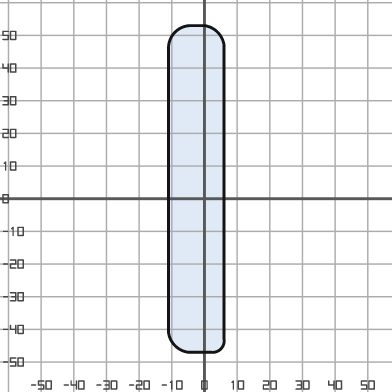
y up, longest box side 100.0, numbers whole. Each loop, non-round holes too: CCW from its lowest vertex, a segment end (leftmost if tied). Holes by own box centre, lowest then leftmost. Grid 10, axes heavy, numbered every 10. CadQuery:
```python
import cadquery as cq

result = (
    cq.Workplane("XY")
    .moveTo(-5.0, -47.0)
    .lineTo(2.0, -47.0)
    .threePointArc((5.0, -46.0), (6.0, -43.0))
    .lineTo(6.0, 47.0)
    .threePointArc((4.0, 51.0), (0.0, 53.0))
    .lineTo(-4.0, 53.0)
    .threePointArc((-9.0, 51.0), (-11.0, 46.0))
    .lineTo(-11.0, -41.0)
    .threePointArc((-9.0, -45.0), (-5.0, -47.0))
    .close()
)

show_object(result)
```